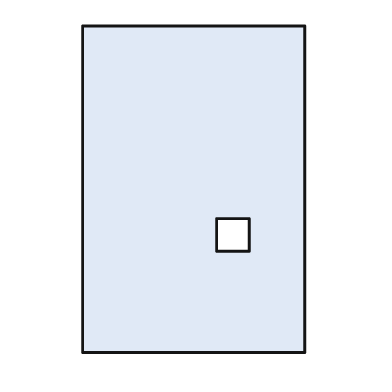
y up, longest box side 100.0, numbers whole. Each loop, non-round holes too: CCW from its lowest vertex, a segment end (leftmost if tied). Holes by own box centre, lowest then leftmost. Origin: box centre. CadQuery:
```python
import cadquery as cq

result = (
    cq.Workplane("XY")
    .moveTo(-34.0, -50.0)
    .lineTo(34.0, -50.0)
    .lineTo(34.0, 50.0)
    .lineTo(-34.0, 50.0)
    .close()
    .moveTo(7.0, -19.0)
    .lineTo(17.0, -19.0)
    .lineTo(17.0, -9.0)
    .lineTo(7.0, -9.0)
    .close()
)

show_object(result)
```